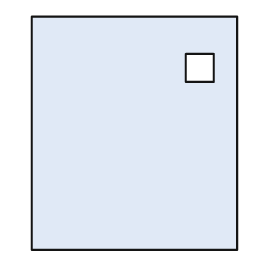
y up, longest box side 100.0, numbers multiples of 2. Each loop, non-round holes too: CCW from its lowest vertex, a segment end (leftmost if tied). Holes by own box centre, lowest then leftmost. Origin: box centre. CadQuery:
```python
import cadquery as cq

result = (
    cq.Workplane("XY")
    .moveTo(-44.0, -50.0)
    .lineTo(44.0, -50.0)
    .lineTo(44.0, 50.0)
    .lineTo(-44.0, 50.0)
    .close()
    .moveTo(22.0, 22.0)
    .lineTo(34.0, 22.0)
    .lineTo(34.0, 34.0)
    .lineTo(22.0, 34.0)
    .close()
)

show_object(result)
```